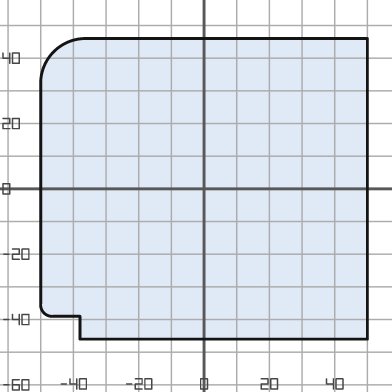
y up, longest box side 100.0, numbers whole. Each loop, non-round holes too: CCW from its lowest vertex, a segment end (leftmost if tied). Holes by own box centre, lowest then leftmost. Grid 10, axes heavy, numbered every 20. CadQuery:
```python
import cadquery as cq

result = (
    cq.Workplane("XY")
    .moveTo(-38.0, -46.0)
    .lineTo(50.0, -46.0)
    .lineTo(50.0, 46.0)
    .lineTo(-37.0, 46.0)
    .threePointArc((-46.0, 42.0), (-50.0, 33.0))
    .lineTo(-50.0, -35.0)
    .threePointArc((-49.0, -38.0), (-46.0, -39.0))
    .lineTo(-38.0, -39.0)
    .close()
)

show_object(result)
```